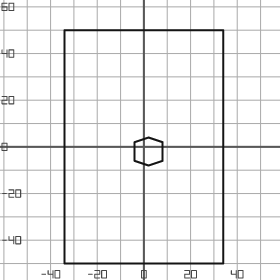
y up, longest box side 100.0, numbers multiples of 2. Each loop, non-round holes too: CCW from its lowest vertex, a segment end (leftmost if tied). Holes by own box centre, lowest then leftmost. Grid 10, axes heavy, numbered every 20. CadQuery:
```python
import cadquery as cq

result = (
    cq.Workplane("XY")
    .moveTo(-34.0, -50.0)
    .lineTo(34.0, -50.0)
    .lineTo(34.0, 50.0)
    .lineTo(-34.0, 50.0)
    .close()
    .moveTo(2.0, -8.0)
    .lineTo(8.0, -6.0)
    .lineTo(8.0, 2.0)
    .lineTo(2.0, 4.0)
    .lineTo(-4.0, 2.0)
    .lineTo(-4.0, -6.0)
    .close()
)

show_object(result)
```